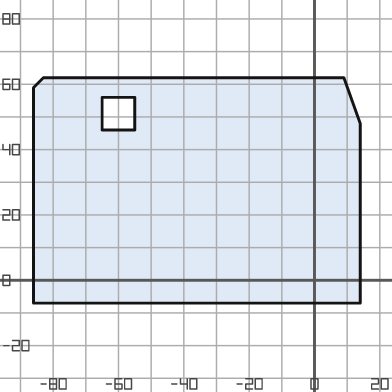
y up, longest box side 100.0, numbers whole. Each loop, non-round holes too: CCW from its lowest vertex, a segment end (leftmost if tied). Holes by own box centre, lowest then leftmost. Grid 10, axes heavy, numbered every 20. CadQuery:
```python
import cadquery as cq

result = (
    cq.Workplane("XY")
    .moveTo(-86.0, -7.0)
    .lineTo(14.0, -7.0)
    .lineTo(14.0, 48.0)
    .lineTo(9.0, 62.0)
    .lineTo(-83.0, 62.0)
    .lineTo(-86.0, 59.0)
    .close()
    .moveTo(-65.0, 46.0)
    .lineTo(-55.0, 46.0)
    .lineTo(-55.0, 56.0)
    .lineTo(-65.0, 56.0)
    .close()
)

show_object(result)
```